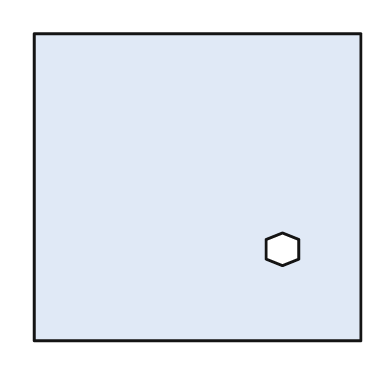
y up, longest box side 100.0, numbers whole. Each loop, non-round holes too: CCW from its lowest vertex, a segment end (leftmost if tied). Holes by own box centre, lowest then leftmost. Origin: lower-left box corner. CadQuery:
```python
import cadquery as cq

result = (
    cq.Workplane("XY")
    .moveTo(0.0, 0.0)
    .lineTo(100.0, 0.0)
    .lineTo(100.0, 94.0)
    .lineTo(0.0, 94.0)
    .close()
    .moveTo(76.0, 23.0)
    .lineTo(81.0, 25.0)
    .lineTo(81.0, 31.0)
    .lineTo(76.0, 33.0)
    .lineTo(71.0, 31.0)
    .lineTo(71.0, 25.0)
    .close()
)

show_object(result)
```